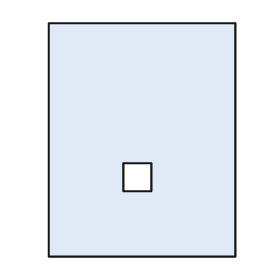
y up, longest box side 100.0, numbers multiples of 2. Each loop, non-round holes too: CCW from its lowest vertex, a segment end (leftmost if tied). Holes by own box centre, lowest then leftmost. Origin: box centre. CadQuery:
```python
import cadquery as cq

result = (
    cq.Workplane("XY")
    .moveTo(-40.0, -50.0)
    .lineTo(40.0, -50.0)
    .lineTo(40.0, 50.0)
    .lineTo(-40.0, 50.0)
    .close()
    .moveTo(-8.0, -22.0)
    .lineTo(4.0, -22.0)
    .lineTo(4.0, -10.0)
    .lineTo(-8.0, -10.0)
    .close()
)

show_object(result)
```